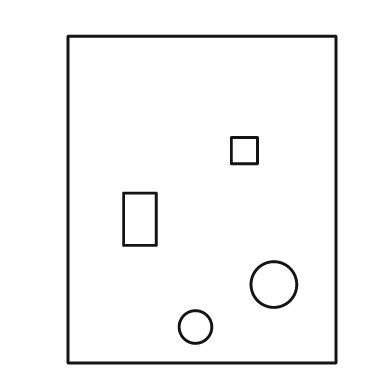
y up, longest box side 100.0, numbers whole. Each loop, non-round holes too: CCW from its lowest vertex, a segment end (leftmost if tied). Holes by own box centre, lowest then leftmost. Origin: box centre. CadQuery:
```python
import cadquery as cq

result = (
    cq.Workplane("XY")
    .moveTo(-41.0, -50.0)
    .lineTo(41.0, -50.0)
    .lineTo(41.0, 50.0)
    .lineTo(-41.0, 50.0)
    .close()
    .moveTo(-2.0, -39.0)
    .circle(5.0)
    .moveTo(22.0, -26.0)
    .circle(7.0)
    .moveTo(-24.0, -14.0)
    .lineTo(-14.0, -14.0)
    .lineTo(-14.0, 2.0)
    .lineTo(-24.0, 2.0)
    .close()
    .moveTo(9.0, 11.0)
    .lineTo(17.0, 11.0)
    .lineTo(17.0, 19.0)
    .lineTo(9.0, 19.0)
    .close()
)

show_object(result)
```